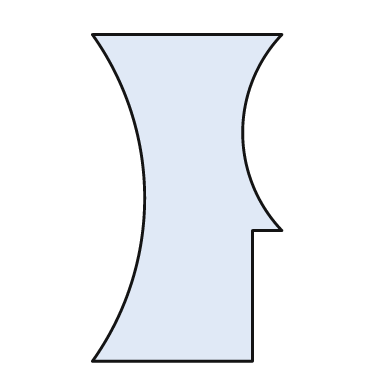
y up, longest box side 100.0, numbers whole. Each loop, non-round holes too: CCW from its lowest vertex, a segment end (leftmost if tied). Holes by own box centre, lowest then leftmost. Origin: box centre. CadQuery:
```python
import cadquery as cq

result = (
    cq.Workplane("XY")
    .moveTo(-29.0, -50.0)
    .lineTo(20.0, -50.0)
    .lineTo(20.0, -10.0)
    .lineTo(29.0, -10.0)
    .threePointArc((17.0, 20.0), (29.0, 50.0))
    .lineTo(-29.0, 50.0)
    .threePointArc((-13.0, 0.0), (-29.0, -50.0))
    .close()
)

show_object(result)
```